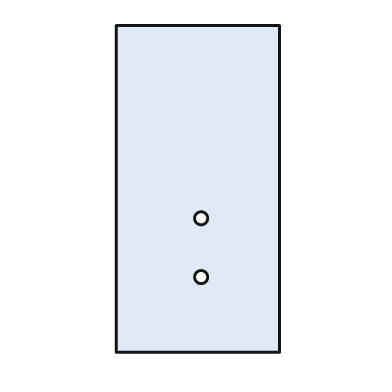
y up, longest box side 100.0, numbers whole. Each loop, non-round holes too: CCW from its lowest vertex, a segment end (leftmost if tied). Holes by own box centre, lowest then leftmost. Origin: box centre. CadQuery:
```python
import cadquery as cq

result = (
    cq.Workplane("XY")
    .moveTo(-25.0, -50.0)
    .lineTo(25.0, -50.0)
    .lineTo(25.0, 50.0)
    .lineTo(-25.0, 50.0)
    .close()
    .moveTo(1.0, -27.0)
    .circle(2.0)
    .moveTo(1.0, -9.0)
    .circle(2.0)
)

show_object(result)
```